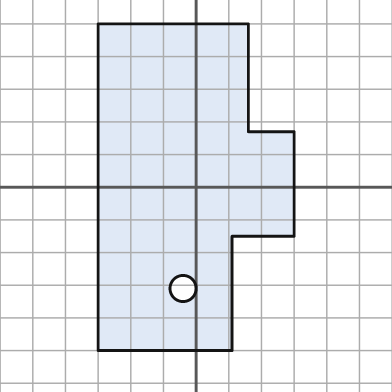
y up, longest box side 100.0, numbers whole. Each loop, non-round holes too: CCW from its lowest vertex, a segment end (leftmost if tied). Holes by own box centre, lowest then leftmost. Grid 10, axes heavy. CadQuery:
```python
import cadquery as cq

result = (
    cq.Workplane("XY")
    .moveTo(-30.0, -50.0)
    .lineTo(11.0, -50.0)
    .lineTo(11.0, -15.0)
    .lineTo(30.0, -15.0)
    .lineTo(30.0, 17.0)
    .lineTo(16.0, 17.0)
    .lineTo(16.0, 50.0)
    .lineTo(-30.0, 50.0)
    .close()
    .moveTo(-4.0, -31.0)
    .circle(4.0)
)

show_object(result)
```